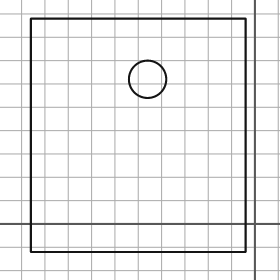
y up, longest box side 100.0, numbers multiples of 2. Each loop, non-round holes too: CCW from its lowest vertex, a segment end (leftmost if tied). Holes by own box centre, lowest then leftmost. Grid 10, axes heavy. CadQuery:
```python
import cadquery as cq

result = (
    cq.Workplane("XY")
    .moveTo(-96.0, -12.0)
    .lineTo(-4.0, -12.0)
    .lineTo(-4.0, 88.0)
    .lineTo(-96.0, 88.0)
    .close()
    .moveTo(-46.0, 62.0)
    .circle(8.0)
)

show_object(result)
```